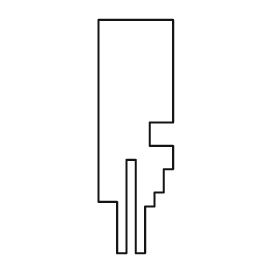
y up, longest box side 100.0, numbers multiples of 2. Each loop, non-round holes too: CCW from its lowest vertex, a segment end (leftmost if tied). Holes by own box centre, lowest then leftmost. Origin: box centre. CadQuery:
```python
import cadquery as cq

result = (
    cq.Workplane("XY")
    .moveTo(-8.0, -50.0)
    .lineTo(-4.0, -50.0)
    .lineTo(-4.0, -10.0)
    .lineTo(0.0, -10.0)
    .lineTo(0.0, -50.0)
    .lineTo(4.0, -50.0)
    .lineTo(4.0, -30.0)
    .lineTo(8.0, -30.0)
    .lineTo(8.0, -24.0)
    .lineTo(12.0, -24.0)
    .lineTo(12.0, -14.0)
    .lineTo(16.0, -14.0)
    .lineTo(16.0, -4.0)
    .lineTo(6.0, -4.0)
    .lineTo(6.0, 6.0)
    .lineTo(16.0, 6.0)
    .lineTo(16.0, 50.0)
    .lineTo(-16.0, 50.0)
    .lineTo(-16.0, -28.0)
    .lineTo(-8.0, -28.0)
    .close()
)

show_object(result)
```